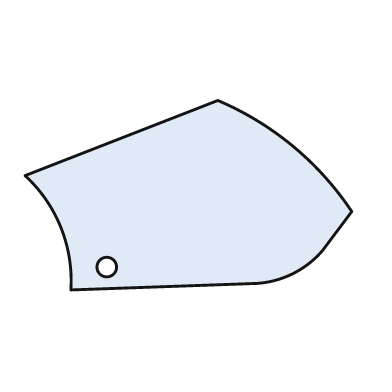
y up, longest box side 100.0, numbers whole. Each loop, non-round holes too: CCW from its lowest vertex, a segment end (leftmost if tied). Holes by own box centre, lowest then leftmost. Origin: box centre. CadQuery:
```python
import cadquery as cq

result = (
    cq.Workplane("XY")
    .moveTo(-36.0, -29.0)
    .lineTo(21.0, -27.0)
    .threePointArc((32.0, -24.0), (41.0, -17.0))
    .lineTo(50.0, -5.0)
    .threePointArc((32.0, 15.0), (9.0, 29.0))
    .lineTo(-50.0, 6.0)
    .threePointArc((-39.0, -10.0), (-36.0, -29.0))
    .close()
    .moveTo(-25.0, -22.0)
    .circle(3.0)
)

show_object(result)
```